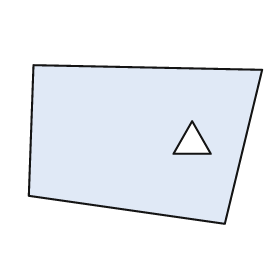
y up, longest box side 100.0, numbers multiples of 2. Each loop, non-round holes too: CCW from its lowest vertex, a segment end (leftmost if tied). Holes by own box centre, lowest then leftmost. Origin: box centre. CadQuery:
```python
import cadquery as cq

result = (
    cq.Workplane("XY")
    .moveTo(34.0, -34.0)
    .lineTo(50.0, 32.0)
    .lineTo(-48.0, 34.0)
    .lineTo(-50.0, -22.0)
    .close()
    .moveTo(12.0, -4.0)
    .lineTo(28.0, -4.0)
    .lineTo(20.0, 10.0)
    .close()
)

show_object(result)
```